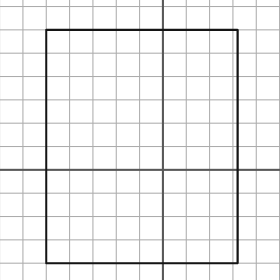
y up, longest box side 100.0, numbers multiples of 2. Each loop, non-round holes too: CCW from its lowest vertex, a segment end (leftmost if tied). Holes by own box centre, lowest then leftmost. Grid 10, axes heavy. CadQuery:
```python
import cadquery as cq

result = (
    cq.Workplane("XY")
    .moveTo(-50.0, -40.0)
    .lineTo(32.0, -40.0)
    .lineTo(32.0, 60.0)
    .lineTo(-50.0, 60.0)
    .close()
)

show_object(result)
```